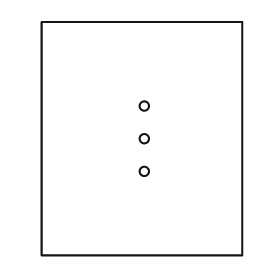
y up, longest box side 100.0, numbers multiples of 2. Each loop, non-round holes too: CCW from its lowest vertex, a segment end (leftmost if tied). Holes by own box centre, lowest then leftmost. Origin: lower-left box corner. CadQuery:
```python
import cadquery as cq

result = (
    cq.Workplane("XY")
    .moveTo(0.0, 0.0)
    .lineTo(86.0, 0.0)
    .lineTo(86.0, 100.0)
    .lineTo(0.0, 100.0)
    .close()
    .moveTo(44.0, 36.0)
    .circle(2.0)
    .moveTo(44.0, 50.0)
    .circle(2.0)
    .moveTo(44.0, 64.0)
    .circle(2.0)
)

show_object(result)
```